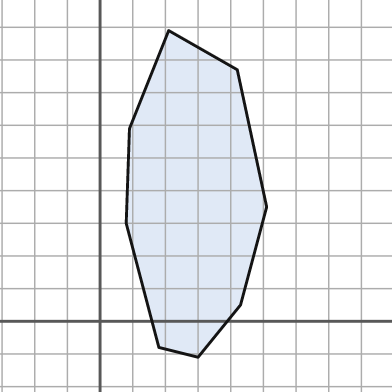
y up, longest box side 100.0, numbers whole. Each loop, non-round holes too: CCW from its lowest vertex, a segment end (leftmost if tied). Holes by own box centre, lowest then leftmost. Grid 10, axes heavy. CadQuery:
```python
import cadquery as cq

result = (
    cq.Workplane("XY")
    .moveTo(30.0, -11.0)
    .lineTo(43.0, 5.0)
    .lineTo(51.0, 35.0)
    .lineTo(42.0, 77.0)
    .lineTo(21.0, 89.0)
    .lineTo(9.0, 59.0)
    .lineTo(8.0, 30.0)
    .lineTo(18.0, -8.0)
    .close()
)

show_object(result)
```